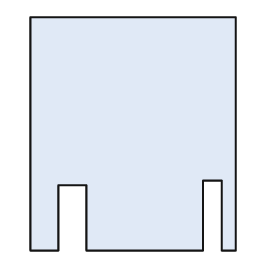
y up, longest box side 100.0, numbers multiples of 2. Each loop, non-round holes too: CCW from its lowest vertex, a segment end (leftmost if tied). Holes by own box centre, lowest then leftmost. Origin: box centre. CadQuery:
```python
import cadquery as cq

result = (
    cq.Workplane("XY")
    .moveTo(-44.0, -50.0)
    .lineTo(-32.0, -50.0)
    .lineTo(-32.0, -22.0)
    .lineTo(-20.0, -22.0)
    .lineTo(-20.0, -50.0)
    .lineTo(30.0, -50.0)
    .lineTo(30.0, -20.0)
    .lineTo(38.0, -20.0)
    .lineTo(38.0, -50.0)
    .lineTo(44.0, -50.0)
    .lineTo(44.0, 50.0)
    .lineTo(-44.0, 50.0)
    .close()
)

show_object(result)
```